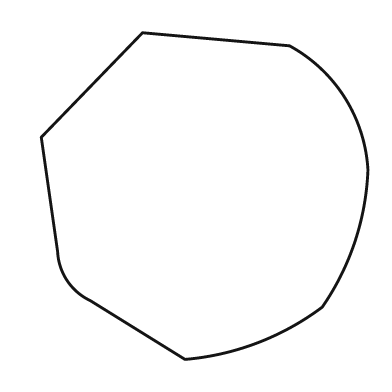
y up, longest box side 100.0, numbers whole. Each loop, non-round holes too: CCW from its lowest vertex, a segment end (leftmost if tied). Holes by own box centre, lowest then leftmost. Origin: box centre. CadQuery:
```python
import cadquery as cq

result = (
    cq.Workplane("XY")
    .moveTo(-6.0, -50.0)
    .threePointArc((16.0, -45.0), (36.0, -34.0))
    .threePointArc((46.0, -14.0), (50.0, 8.0))
    .threePointArc((43.0, 30.0), (26.0, 46.0))
    .lineTo(-19.0, 50.0)
    .lineTo(-50.0, 18.0)
    .lineTo(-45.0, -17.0)
    .threePointArc((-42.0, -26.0), (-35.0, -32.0))
    .close()
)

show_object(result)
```